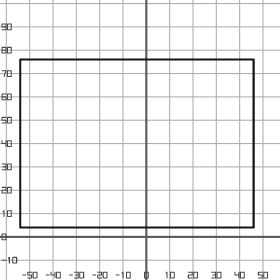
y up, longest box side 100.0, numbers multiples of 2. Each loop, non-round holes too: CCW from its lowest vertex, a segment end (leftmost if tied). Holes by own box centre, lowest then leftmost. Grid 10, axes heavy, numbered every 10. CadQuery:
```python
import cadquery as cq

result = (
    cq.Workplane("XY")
    .moveTo(-54.0, 4.0)
    .lineTo(46.0, 4.0)
    .lineTo(46.0, 76.0)
    .lineTo(-54.0, 76.0)
    .close()
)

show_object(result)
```